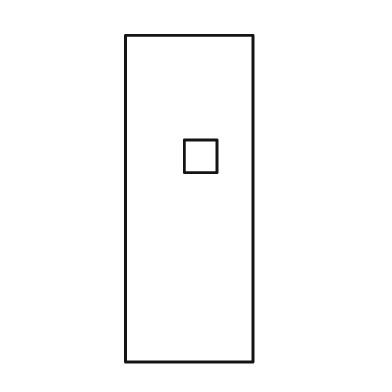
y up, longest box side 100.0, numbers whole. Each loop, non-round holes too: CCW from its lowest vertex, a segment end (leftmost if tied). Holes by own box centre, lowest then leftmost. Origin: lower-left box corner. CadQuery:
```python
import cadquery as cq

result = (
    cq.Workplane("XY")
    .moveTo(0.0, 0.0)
    .lineTo(39.0, 0.0)
    .lineTo(39.0, 100.0)
    .lineTo(0.0, 100.0)
    .close()
    .moveTo(18.0, 58.0)
    .lineTo(28.0, 58.0)
    .lineTo(28.0, 68.0)
    .lineTo(18.0, 68.0)
    .close()
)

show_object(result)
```